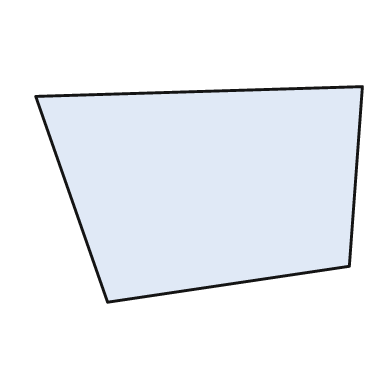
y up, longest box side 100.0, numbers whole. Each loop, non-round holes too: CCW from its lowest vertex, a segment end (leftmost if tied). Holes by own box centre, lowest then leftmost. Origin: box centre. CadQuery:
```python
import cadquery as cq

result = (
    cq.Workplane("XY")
    .moveTo(-28.0, -33.0)
    .lineTo(46.0, -22.0)
    .lineTo(50.0, 33.0)
    .lineTo(-50.0, 30.0)
    .close()
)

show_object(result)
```